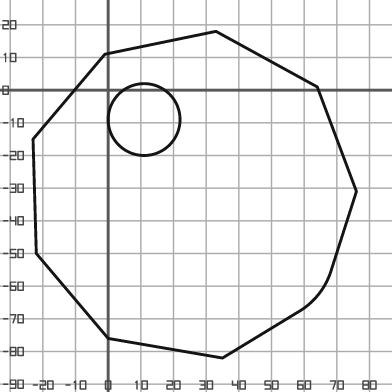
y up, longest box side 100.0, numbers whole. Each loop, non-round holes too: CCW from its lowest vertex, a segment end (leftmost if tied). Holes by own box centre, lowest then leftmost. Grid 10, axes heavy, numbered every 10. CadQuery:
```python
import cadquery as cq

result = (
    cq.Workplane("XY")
    .moveTo(35.0, -82.0)
    .lineTo(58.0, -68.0)
    .threePointArc((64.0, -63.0), (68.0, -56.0))
    .lineTo(76.0, -31.0)
    .lineTo(64.0, 1.0)
    .lineTo(33.0, 18.0)
    .lineTo(-1.0, 11.0)
    .lineTo(-23.0, -15.0)
    .lineTo(-22.0, -50.0)
    .lineTo(0.0, -76.0)
    .close()
    .moveTo(11.0, -9.0)
    .circle(11.0)
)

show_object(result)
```